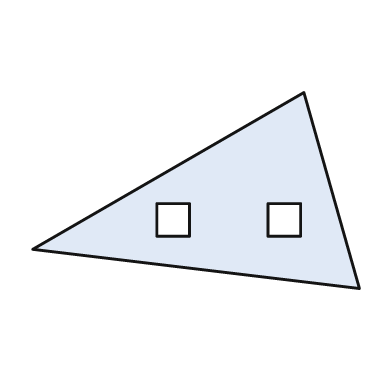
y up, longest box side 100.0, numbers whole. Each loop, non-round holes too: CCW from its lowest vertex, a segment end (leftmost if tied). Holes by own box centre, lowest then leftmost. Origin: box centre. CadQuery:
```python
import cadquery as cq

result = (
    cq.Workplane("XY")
    .moveTo(50.0, -30.0)
    .lineTo(33.0, 30.0)
    .lineTo(-50.0, -18.0)
    .close()
    .moveTo(-12.0, -14.0)
    .lineTo(-2.0, -14.0)
    .lineTo(-2.0, -4.0)
    .lineTo(-12.0, -4.0)
    .close()
    .moveTo(22.0, -14.0)
    .lineTo(32.0, -14.0)
    .lineTo(32.0, -4.0)
    .lineTo(22.0, -4.0)
    .close()
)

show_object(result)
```